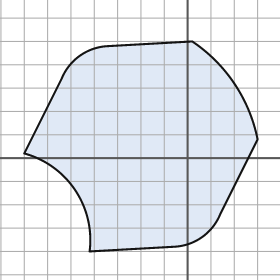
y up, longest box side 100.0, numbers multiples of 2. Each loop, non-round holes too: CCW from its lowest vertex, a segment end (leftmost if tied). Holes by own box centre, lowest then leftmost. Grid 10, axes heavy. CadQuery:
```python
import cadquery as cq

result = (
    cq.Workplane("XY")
    .moveTo(-42.0, -40.0)
    .lineTo(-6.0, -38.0)
    .threePointArc((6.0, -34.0), (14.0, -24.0))
    .lineTo(30.0, 8.0)
    .threePointArc((20.0, 32.0), (2.0, 50.0))
    .lineTo(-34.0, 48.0)
    .threePointArc((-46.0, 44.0), (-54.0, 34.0))
    .lineTo(-70.0, 2.0)
    .threePointArc((-48.0, -14.0), (-42.0, -40.0))
    .close()
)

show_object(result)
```